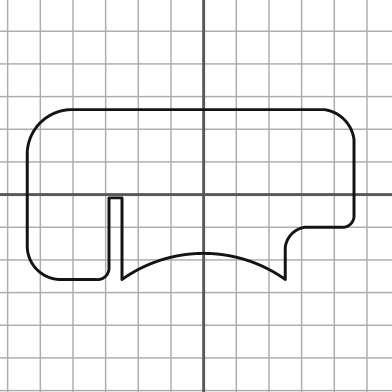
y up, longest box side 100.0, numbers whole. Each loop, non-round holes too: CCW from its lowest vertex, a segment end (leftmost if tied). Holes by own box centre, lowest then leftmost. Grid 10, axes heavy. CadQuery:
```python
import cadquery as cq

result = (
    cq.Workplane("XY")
    .moveTo(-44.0, -26.0)
    .lineTo(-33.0, -26.0)
    .threePointArc((-30.0, -25.0), (-29.0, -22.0))
    .lineTo(-29.0, -1.0)
    .lineTo(-25.0, -1.0)
    .lineTo(-25.0, -26.0)
    .threePointArc((0.0, -18.0), (25.0, -26.0))
    .lineTo(25.0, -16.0)
    .threePointArc((27.0, -12.0), (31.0, -10.0))
    .lineTo(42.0, -10.0)
    .threePointArc((45.0, -9.0), (46.0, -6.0))
    .lineTo(46.0, 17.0)
    .threePointArc((43.0, 23.0), (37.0, 26.0))
    .lineTo(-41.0, 26.0)
    .threePointArc((-50.0, 22.0), (-54.0, 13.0))
    .lineTo(-54.0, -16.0)
    .threePointArc((-51.0, -23.0), (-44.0, -26.0))
    .close()
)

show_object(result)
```